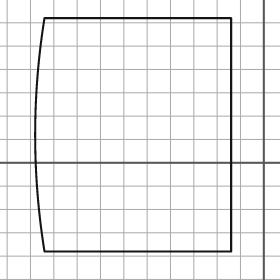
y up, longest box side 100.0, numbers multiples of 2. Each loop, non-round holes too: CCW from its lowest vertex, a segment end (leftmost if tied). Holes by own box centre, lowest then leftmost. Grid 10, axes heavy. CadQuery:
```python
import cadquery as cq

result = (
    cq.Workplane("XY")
    .moveTo(-94.0, -38.0)
    .lineTo(-14.0, -38.0)
    .lineTo(-14.0, 62.0)
    .lineTo(-94.0, 62.0)
    .threePointArc((-98.0, 12.0), (-94.0, -38.0))
    .close()
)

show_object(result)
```